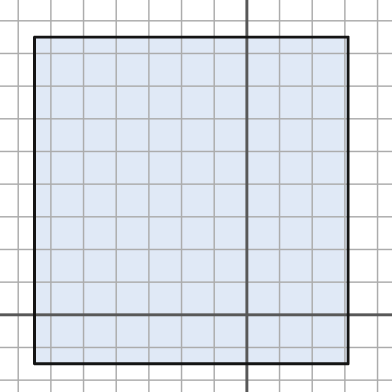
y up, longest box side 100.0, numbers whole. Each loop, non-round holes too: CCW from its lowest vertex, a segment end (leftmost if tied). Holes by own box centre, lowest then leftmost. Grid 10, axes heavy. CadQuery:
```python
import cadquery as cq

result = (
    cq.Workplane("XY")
    .moveTo(-65.0, -15.0)
    .lineTo(31.0, -15.0)
    .lineTo(31.0, 85.0)
    .lineTo(-65.0, 85.0)
    .close()
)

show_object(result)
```